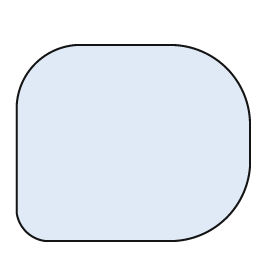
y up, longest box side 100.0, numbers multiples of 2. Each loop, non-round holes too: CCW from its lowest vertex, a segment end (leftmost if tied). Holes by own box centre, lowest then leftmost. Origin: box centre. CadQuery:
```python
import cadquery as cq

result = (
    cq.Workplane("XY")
    .moveTo(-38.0, -42.0)
    .lineTo(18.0, -42.0)
    .threePointArc((40.0, -32.0), (50.0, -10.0))
    .lineTo(50.0, 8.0)
    .threePointArc((40.0, 32.0), (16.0, 42.0))
    .lineTo(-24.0, 42.0)
    .threePointArc((-42.0, 34.0), (-50.0, 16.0))
    .lineTo(-50.0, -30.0)
    .threePointArc((-46.0, -38.0), (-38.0, -42.0))
    .close()
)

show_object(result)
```